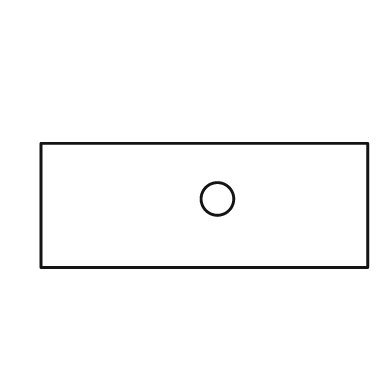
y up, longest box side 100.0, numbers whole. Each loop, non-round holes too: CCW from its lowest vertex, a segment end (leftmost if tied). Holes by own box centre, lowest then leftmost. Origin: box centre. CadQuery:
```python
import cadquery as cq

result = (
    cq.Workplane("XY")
    .moveTo(-50.0, -19.0)
    .lineTo(50.0, -19.0)
    .lineTo(50.0, 19.0)
    .lineTo(-50.0, 19.0)
    .close()
    .moveTo(4.0, 2.0)
    .circle(5.0)
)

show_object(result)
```